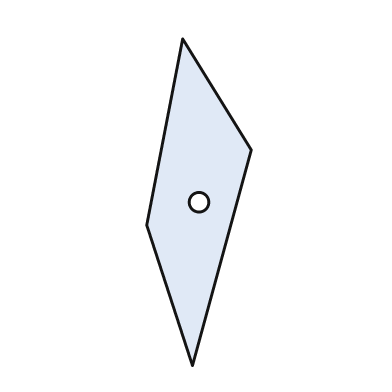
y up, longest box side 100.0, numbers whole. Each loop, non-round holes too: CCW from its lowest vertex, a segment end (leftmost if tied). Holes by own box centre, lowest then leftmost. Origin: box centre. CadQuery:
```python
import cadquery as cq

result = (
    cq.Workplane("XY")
    .moveTo(-2.0, -50.0)
    .lineTo(16.0, 16.0)
    .lineTo(-5.0, 50.0)
    .lineTo(-16.0, -7.0)
    .close()
    .moveTo(0.0, 0.0)
    .circle(3.0)
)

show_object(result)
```